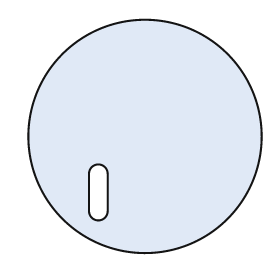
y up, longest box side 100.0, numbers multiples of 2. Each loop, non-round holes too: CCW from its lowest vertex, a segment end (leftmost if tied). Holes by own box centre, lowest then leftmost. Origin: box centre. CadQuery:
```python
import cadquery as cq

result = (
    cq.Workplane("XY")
    .moveTo(0.0, 0.0)
    .circle(50.0)
    .moveTo(-24.0, -32.0)
    .threePointArc((-20.0, -36.0), (-16.0, -32.0))
    .lineTo(-16.0, -16.0)
    .threePointArc((-20.0, -12.0), (-24.0, -16.0))
    .close()
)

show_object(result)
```